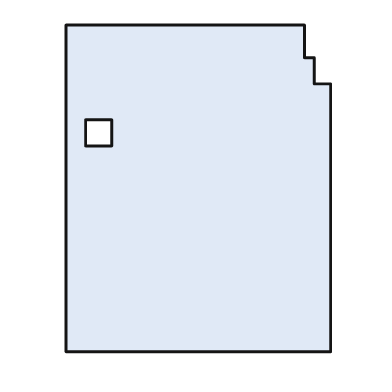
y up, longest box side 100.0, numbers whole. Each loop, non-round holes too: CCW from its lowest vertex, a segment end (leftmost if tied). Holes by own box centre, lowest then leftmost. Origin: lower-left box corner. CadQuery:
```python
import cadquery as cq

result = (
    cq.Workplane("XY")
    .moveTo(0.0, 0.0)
    .lineTo(81.0, 0.0)
    .lineTo(81.0, 82.0)
    .lineTo(76.0, 82.0)
    .lineTo(76.0, 90.0)
    .lineTo(73.0, 90.0)
    .lineTo(73.0, 100.0)
    .lineTo(0.0, 100.0)
    .close()
    .moveTo(6.0, 63.0)
    .lineTo(14.0, 63.0)
    .lineTo(14.0, 71.0)
    .lineTo(6.0, 71.0)
    .close()
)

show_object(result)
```